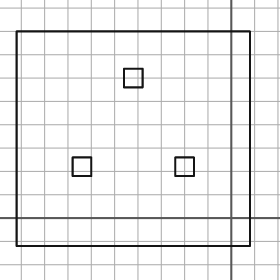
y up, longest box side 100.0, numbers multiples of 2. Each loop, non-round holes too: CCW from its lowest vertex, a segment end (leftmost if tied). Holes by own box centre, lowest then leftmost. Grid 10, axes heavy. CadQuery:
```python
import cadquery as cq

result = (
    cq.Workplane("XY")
    .moveTo(-92.0, -12.0)
    .lineTo(8.0, -12.0)
    .lineTo(8.0, 80.0)
    .lineTo(-92.0, 80.0)
    .close()
    .moveTo(-68.0, 18.0)
    .lineTo(-60.0, 18.0)
    .lineTo(-60.0, 26.0)
    .lineTo(-68.0, 26.0)
    .close()
    .moveTo(-24.0, 18.0)
    .lineTo(-16.0, 18.0)
    .lineTo(-16.0, 26.0)
    .lineTo(-24.0, 26.0)
    .close()
    .moveTo(-46.0, 56.0)
    .lineTo(-38.0, 56.0)
    .lineTo(-38.0, 64.0)
    .lineTo(-46.0, 64.0)
    .close()
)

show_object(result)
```